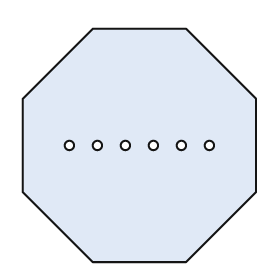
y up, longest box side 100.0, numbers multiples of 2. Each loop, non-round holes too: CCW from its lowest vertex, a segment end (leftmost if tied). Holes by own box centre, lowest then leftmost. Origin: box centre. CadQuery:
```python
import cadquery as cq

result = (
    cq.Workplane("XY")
    .moveTo(-20.0, -50.0)
    .lineTo(20.0, -50.0)
    .lineTo(50.0, -20.0)
    .lineTo(50.0, 20.0)
    .lineTo(20.0, 50.0)
    .lineTo(-20.0, 50.0)
    .lineTo(-50.0, 20.0)
    .lineTo(-50.0, -20.0)
    .close()
    .moveTo(-30.0, 0.0)
    .circle(2.0)
    .moveTo(-18.0, 0.0)
    .circle(2.0)
    .moveTo(-6.0, 0.0)
    .circle(2.0)
    .moveTo(6.0, 0.0)
    .circle(2.0)
    .moveTo(18.0, 0.0)
    .circle(2.0)
    .moveTo(30.0, 0.0)
    .circle(2.0)
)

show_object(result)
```